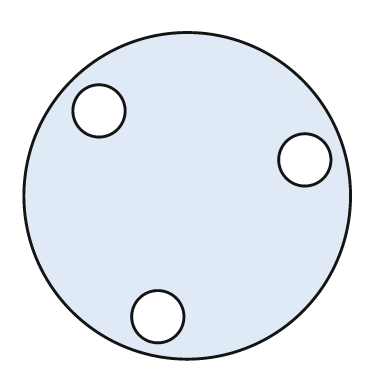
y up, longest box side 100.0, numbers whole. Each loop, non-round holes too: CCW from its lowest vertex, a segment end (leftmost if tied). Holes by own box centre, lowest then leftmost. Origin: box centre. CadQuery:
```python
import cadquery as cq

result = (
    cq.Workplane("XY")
    .moveTo(0.0, 0.0)
    .circle(50.0)
    .moveTo(-9.0, -37.0)
    .circle(8.0)
    .moveTo(36.0, 11.0)
    .circle(8.0)
    .moveTo(-27.0, 26.0)
    .circle(8.0)
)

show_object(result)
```